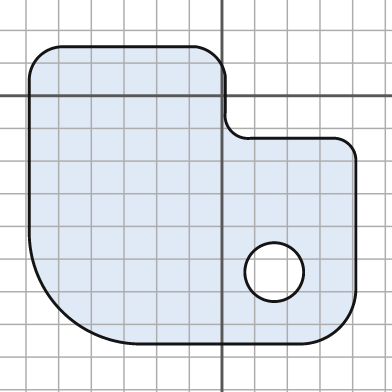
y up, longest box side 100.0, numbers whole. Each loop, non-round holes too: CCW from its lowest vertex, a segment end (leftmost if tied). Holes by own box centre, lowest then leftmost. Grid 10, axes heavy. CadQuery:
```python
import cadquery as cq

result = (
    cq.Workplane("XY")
    .moveTo(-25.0, -76.0)
    .lineTo(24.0, -76.0)
    .threePointArc((36.0, -71.0), (41.0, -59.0))
    .lineTo(41.0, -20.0)
    .threePointArc((39.0, -15.0), (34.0, -13.0))
    .lineTo(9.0, -13.0)
    .threePointArc((3.0, -11.0), (1.0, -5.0))
    .lineTo(1.0, 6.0)
    .threePointArc((-2.0, 12.0), (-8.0, 15.0))
    .lineTo(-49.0, 15.0)
    .threePointArc((-56.0, 12.0), (-59.0, 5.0))
    .lineTo(-59.0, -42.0)
    .threePointArc((-49.0, -66.0), (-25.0, -76.0))
    .close()
    .moveTo(16.0, -54.0)
    .circle(9.0)
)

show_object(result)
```